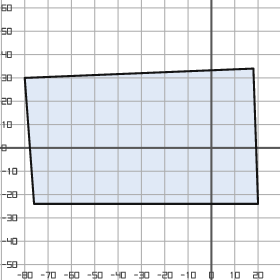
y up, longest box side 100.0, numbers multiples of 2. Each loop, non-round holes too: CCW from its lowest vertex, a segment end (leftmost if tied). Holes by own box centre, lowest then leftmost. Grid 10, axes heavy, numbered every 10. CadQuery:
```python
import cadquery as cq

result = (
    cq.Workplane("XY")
    .moveTo(-76.0, -24.0)
    .lineTo(20.0, -24.0)
    .lineTo(18.0, 34.0)
    .lineTo(-80.0, 30.0)
    .close()
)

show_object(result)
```